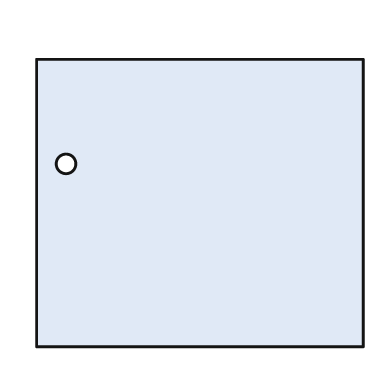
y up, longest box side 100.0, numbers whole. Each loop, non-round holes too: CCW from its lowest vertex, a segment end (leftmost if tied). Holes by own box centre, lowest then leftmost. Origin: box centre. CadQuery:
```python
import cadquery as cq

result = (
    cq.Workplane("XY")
    .moveTo(-50.0, -44.0)
    .lineTo(50.0, -44.0)
    .lineTo(50.0, 44.0)
    .lineTo(-50.0, 44.0)
    .close()
    .moveTo(-41.0, 12.0)
    .circle(3.0)
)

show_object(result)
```